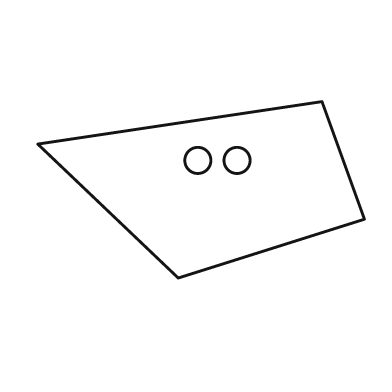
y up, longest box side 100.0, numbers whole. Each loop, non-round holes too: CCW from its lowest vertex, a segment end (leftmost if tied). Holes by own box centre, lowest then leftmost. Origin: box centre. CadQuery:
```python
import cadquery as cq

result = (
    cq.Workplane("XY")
    .moveTo(-7.0, -27.0)
    .lineTo(50.0, -9.0)
    .lineTo(37.0, 27.0)
    .lineTo(-50.0, 14.0)
    .close()
    .moveTo(-1.0, 9.0)
    .circle(4.0)
    .moveTo(11.0, 9.0)
    .circle(4.0)
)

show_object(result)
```